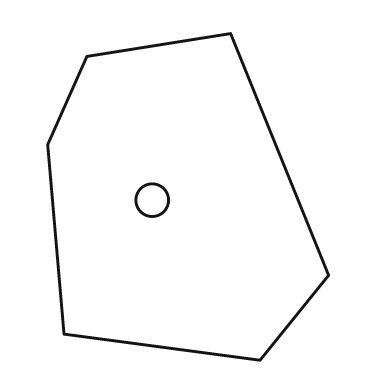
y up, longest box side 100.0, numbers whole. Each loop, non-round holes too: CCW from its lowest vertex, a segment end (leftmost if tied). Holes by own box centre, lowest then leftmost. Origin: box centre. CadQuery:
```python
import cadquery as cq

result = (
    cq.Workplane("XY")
    .moveTo(22.0, -50.0)
    .lineTo(43.0, -24.0)
    .lineTo(13.0, 50.0)
    .lineTo(-31.0, 43.0)
    .lineTo(-43.0, 16.0)
    .lineTo(-38.0, -42.0)
    .close()
    .moveTo(-11.0, -1.0)
    .circle(5.0)
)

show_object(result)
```